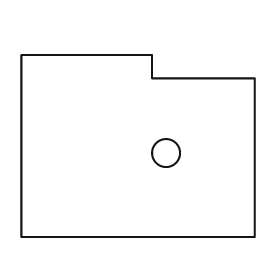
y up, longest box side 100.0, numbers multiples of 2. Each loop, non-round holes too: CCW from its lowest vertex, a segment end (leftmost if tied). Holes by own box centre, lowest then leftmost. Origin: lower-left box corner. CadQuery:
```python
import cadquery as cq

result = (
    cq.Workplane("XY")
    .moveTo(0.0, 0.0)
    .lineTo(100.0, 0.0)
    .lineTo(100.0, 68.0)
    .lineTo(56.0, 68.0)
    .lineTo(56.0, 78.0)
    .lineTo(0.0, 78.0)
    .close()
    .moveTo(62.0, 36.0)
    .circle(6.0)
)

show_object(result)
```